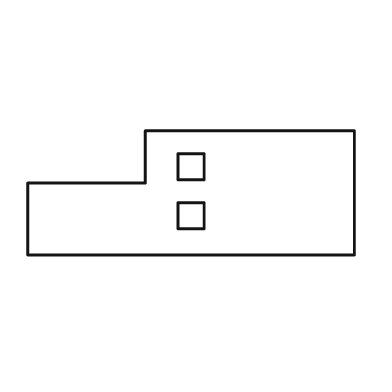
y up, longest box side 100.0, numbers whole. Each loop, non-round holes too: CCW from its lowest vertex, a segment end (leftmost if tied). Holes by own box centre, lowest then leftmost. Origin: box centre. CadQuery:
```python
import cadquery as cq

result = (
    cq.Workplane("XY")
    .moveTo(-50.0, -19.0)
    .lineTo(50.0, -19.0)
    .lineTo(50.0, 19.0)
    .lineTo(-14.0, 19.0)
    .lineTo(-14.0, 3.0)
    .lineTo(-50.0, 3.0)
    .close()
    .moveTo(-4.0, -11.0)
    .lineTo(4.0, -11.0)
    .lineTo(4.0, -3.0)
    .lineTo(-4.0, -3.0)
    .close()
    .moveTo(-4.0, 4.0)
    .lineTo(4.0, 4.0)
    .lineTo(4.0, 12.0)
    .lineTo(-4.0, 12.0)
    .close()
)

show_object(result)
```